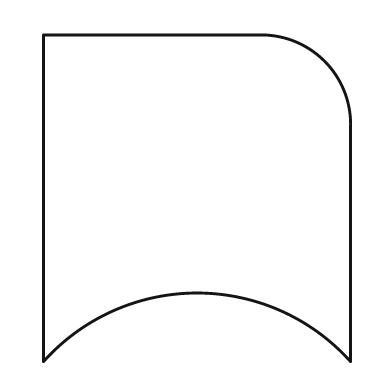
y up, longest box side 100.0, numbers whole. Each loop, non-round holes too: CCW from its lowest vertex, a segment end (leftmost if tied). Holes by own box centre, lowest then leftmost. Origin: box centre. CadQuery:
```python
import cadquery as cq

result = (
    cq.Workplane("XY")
    .moveTo(-47.0, -50.0)
    .threePointArc((0.0, -29.0), (47.0, -50.0))
    .lineTo(47.0, 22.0)
    .threePointArc((39.0, 42.0), (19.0, 50.0))
    .lineTo(-47.0, 50.0)
    .close()
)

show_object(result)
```